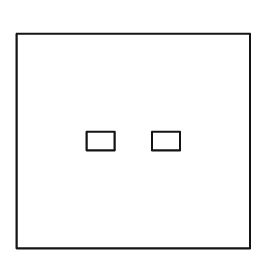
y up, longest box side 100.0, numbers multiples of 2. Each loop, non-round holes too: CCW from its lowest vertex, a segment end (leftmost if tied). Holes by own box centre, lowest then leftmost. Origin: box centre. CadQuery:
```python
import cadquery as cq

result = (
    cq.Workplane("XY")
    .moveTo(-50.0, -46.0)
    .lineTo(50.0, -46.0)
    .lineTo(50.0, 46.0)
    .lineTo(-50.0, 46.0)
    .close()
    .moveTo(-20.0, -4.0)
    .lineTo(-8.0, -4.0)
    .lineTo(-8.0, 4.0)
    .lineTo(-20.0, 4.0)
    .close()
    .moveTo(8.0, -4.0)
    .lineTo(20.0, -4.0)
    .lineTo(20.0, 4.0)
    .lineTo(8.0, 4.0)
    .close()
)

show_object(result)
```